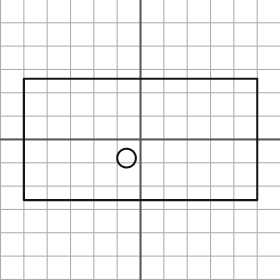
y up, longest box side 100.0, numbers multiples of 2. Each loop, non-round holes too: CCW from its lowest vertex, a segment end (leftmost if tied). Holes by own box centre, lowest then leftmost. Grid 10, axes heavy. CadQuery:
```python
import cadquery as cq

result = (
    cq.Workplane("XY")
    .moveTo(-50.0, -26.0)
    .lineTo(50.0, -26.0)
    .lineTo(50.0, 26.0)
    .lineTo(-50.0, 26.0)
    .close()
    .moveTo(-6.0, -8.0)
    .circle(4.0)
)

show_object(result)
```